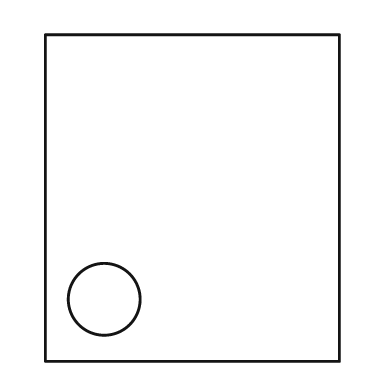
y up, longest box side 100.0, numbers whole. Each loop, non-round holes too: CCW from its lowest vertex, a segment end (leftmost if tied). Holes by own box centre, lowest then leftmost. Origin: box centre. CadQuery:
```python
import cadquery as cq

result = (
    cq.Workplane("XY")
    .moveTo(-45.0, -50.0)
    .lineTo(45.0, -50.0)
    .lineTo(45.0, 50.0)
    .lineTo(-45.0, 50.0)
    .close()
    .moveTo(-27.0, -31.0)
    .circle(11.0)
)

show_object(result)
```